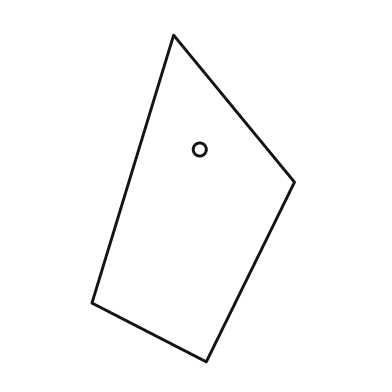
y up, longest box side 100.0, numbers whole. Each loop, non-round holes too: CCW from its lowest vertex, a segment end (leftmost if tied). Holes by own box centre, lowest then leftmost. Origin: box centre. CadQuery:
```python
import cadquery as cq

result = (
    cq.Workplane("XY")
    .moveTo(4.0, -50.0)
    .lineTo(31.0, 5.0)
    .lineTo(-6.0, 50.0)
    .lineTo(-31.0, -32.0)
    .close()
    .moveTo(2.0, 15.0)
    .circle(2.0)
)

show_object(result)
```